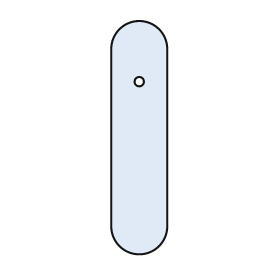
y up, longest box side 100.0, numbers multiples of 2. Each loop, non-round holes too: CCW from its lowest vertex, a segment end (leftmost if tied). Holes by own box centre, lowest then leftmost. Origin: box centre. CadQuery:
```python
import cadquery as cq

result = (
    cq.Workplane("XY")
    .moveTo(-12.0, -38.0)
    .threePointArc((0.0, -50.0), (12.0, -38.0))
    .lineTo(12.0, 38.0)
    .threePointArc((0.0, 50.0), (-12.0, 38.0))
    .close()
    .moveTo(0.0, 24.0)
    .circle(2.0)
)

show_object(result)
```